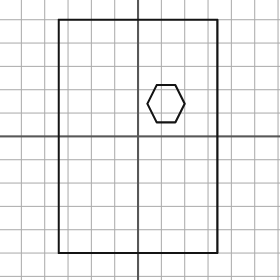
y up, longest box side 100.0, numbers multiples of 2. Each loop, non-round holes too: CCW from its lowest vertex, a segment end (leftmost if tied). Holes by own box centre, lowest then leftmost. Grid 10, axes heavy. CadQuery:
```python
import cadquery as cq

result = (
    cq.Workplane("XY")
    .moveTo(-34.0, -50.0)
    .lineTo(34.0, -50.0)
    .lineTo(34.0, 50.0)
    .lineTo(-34.0, 50.0)
    .close()
    .moveTo(8.0, 6.0)
    .lineTo(16.0, 6.0)
    .lineTo(20.0, 14.0)
    .lineTo(16.0, 22.0)
    .lineTo(8.0, 22.0)
    .lineTo(4.0, 14.0)
    .close()
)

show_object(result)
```